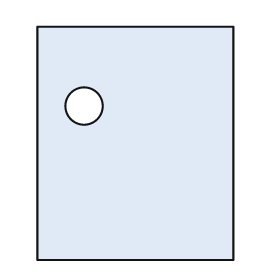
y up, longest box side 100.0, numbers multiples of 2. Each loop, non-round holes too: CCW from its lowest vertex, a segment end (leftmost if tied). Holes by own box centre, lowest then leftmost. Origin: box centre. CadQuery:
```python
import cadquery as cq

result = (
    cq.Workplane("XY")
    .moveTo(-42.0, -50.0)
    .lineTo(42.0, -50.0)
    .lineTo(42.0, 50.0)
    .lineTo(-42.0, 50.0)
    .close()
    .moveTo(-22.0, 16.0)
    .circle(8.0)
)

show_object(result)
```